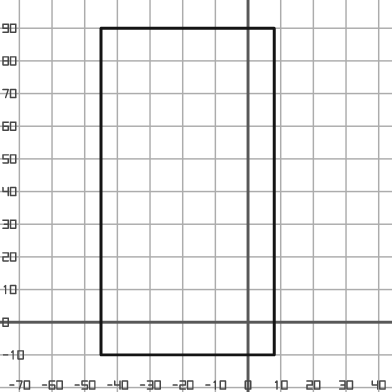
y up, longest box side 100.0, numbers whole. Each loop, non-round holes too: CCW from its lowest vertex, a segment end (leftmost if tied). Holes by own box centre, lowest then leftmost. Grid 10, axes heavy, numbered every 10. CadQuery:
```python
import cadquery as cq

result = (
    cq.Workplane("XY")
    .moveTo(-45.0, -10.0)
    .lineTo(8.0, -10.0)
    .lineTo(8.0, 90.0)
    .lineTo(-45.0, 90.0)
    .close()
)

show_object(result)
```